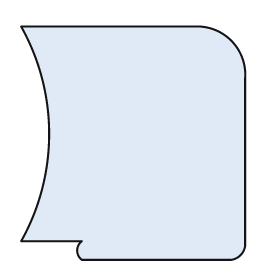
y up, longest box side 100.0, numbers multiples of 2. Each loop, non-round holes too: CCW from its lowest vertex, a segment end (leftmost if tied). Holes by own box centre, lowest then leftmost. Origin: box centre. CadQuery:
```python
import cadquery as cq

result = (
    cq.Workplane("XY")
    .moveTo(-22.0, -50.0)
    .lineTo(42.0, -50.0)
    .threePointArc((46.0, -48.0), (48.0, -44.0))
    .lineTo(48.0, 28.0)
    .threePointArc((42.0, 44.0), (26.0, 50.0))
    .lineTo(-48.0, 50.0)
    .threePointArc((-36.0, 4.0), (-48.0, -42.0))
    .lineTo(-22.0, -42.0)
    .threePointArc((-24.0, -46.0), (-22.0, -50.0))
    .close()
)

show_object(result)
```